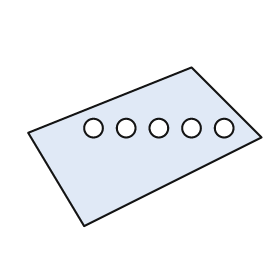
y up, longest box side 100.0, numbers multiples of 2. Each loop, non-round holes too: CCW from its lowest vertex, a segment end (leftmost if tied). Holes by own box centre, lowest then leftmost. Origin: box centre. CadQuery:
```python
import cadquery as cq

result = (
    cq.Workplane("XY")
    .moveTo(-26.0, -34.0)
    .lineTo(50.0, 4.0)
    .lineTo(20.0, 34.0)
    .lineTo(-50.0, 6.0)
    .close()
    .moveTo(-22.0, 8.0)
    .circle(4.0)
    .moveTo(-8.0, 8.0)
    .circle(4.0)
    .moveTo(6.0, 8.0)
    .circle(4.0)
    .moveTo(20.0, 8.0)
    .circle(4.0)
    .moveTo(34.0, 8.0)
    .circle(4.0)
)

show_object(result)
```